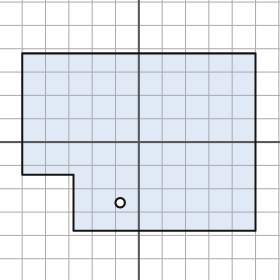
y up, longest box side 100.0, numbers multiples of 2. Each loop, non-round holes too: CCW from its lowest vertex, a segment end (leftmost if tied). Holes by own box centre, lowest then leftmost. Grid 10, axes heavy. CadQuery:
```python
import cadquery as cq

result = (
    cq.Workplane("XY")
    .moveTo(-28.0, -38.0)
    .lineTo(50.0, -38.0)
    .lineTo(50.0, 38.0)
    .lineTo(-50.0, 38.0)
    .lineTo(-50.0, -14.0)
    .lineTo(-28.0, -14.0)
    .close()
    .moveTo(-8.0, -26.0)
    .circle(2.0)
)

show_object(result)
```